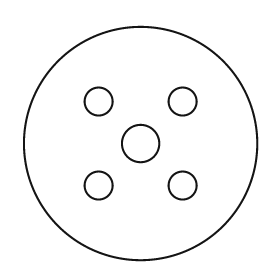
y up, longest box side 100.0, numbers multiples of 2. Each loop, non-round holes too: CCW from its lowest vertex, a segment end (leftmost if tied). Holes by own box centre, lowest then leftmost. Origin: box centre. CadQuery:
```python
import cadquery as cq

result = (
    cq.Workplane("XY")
    .moveTo(0.0, 0.0)
    .circle(50.0)
    .moveTo(-18.0, -18.0)
    .circle(6.0)
    .moveTo(18.0, -18.0)
    .circle(6.0)
    .moveTo(0.0, 0.0)
    .circle(8.0)
    .moveTo(-18.0, 18.0)
    .circle(6.0)
    .moveTo(18.0, 18.0)
    .circle(6.0)
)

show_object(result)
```